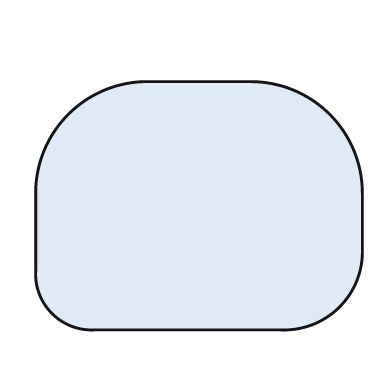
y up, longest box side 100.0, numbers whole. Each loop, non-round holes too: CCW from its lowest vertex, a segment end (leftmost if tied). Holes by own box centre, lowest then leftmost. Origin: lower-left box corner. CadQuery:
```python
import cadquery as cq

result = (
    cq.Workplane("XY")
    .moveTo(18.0, 0.0)
    .lineTo(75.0, 0.0)
    .threePointArc((93.0, 7.0), (100.0, 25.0))
    .lineTo(100.0, 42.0)
    .threePointArc((90.0, 66.0), (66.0, 76.0))
    .lineTo(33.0, 76.0)
    .threePointArc((10.0, 66.0), (0.0, 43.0))
    .lineTo(0.0, 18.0)
    .threePointArc((5.0, 5.0), (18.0, 0.0))
    .close()
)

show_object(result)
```